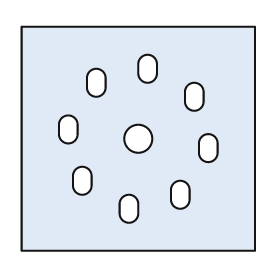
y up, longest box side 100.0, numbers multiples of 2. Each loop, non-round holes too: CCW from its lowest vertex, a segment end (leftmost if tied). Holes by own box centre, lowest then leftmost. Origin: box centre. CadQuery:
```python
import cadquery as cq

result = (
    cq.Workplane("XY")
    .moveTo(-50.0, -48.0)
    .lineTo(50.0, -48.0)
    .lineTo(50.0, 48.0)
    .lineTo(-50.0, 48.0)
    .close()
    .moveTo(-8.0, -32.0)
    .threePointArc((-4.0, -36.0), (0.0, -32.0))
    .lineTo(0.0, -28.0)
    .threePointArc((-4.0, -24.0), (-8.0, -28.0))
    .close()
    .moveTo(14.0, -26.0)
    .threePointArc((18.0, -30.0), (22.0, -26.0))
    .lineTo(22.0, -22.0)
    .threePointArc((18.0, -18.0), (14.0, -22.0))
    .close()
    .moveTo(-28.0, -20.0)
    .threePointArc((-24.0, -24.0), (-20.0, -20.0))
    .lineTo(-20.0, -16.0)
    .threePointArc((-24.0, -12.0), (-28.0, -16.0))
    .close()
    .moveTo(26.0, -6.0)
    .threePointArc((30.0, -10.0), (34.0, -6.0))
    .lineTo(34.0, -2.0)
    .threePointArc((30.0, 2.0), (26.0, -2.0))
    .close()
    .moveTo(0.0, 0.0)
    .circle(6.0)
    .moveTo(-34.0, 2.0)
    .threePointArc((-30.0, -2.0), (-26.0, 2.0))
    .lineTo(-26.0, 6.0)
    .threePointArc((-30.0, 10.0), (-34.0, 6.0))
    .close()
    .moveTo(20.0, 16.0)
    .threePointArc((24.0, 12.0), (28.0, 16.0))
    .lineTo(28.0, 20.0)
    .threePointArc((24.0, 24.0), (20.0, 20.0))
    .close()
    .moveTo(-22.0, 22.0)
    .threePointArc((-18.0, 18.0), (-14.0, 22.0))
    .lineTo(-14.0, 26.0)
    .threePointArc((-18.0, 30.0), (-22.0, 26.0))
    .close()
    .moveTo(0.0, 28.0)
    .threePointArc((4.0, 24.0), (8.0, 28.0))
    .lineTo(8.0, 32.0)
    .threePointArc((4.0, 36.0), (0.0, 32.0))
    .close()
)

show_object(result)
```